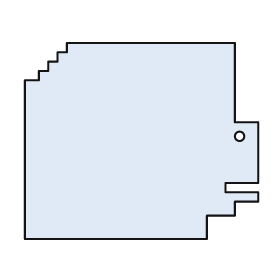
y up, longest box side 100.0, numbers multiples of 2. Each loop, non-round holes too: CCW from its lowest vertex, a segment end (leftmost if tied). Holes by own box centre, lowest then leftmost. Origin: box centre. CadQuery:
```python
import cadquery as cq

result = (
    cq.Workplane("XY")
    .moveTo(-50.0, -42.0)
    .lineTo(28.0, -42.0)
    .lineTo(28.0, -32.0)
    .lineTo(40.0, -32.0)
    .lineTo(40.0, -26.0)
    .lineTo(50.0, -26.0)
    .lineTo(50.0, -22.0)
    .lineTo(36.0, -22.0)
    .lineTo(36.0, -18.0)
    .lineTo(50.0, -18.0)
    .lineTo(50.0, 8.0)
    .lineTo(40.0, 8.0)
    .lineTo(40.0, 42.0)
    .lineTo(-32.0, 42.0)
    .lineTo(-32.0, 38.0)
    .lineTo(-36.0, 38.0)
    .lineTo(-36.0, 34.0)
    .lineTo(-40.0, 34.0)
    .lineTo(-40.0, 30.0)
    .lineTo(-44.0, 30.0)
    .lineTo(-44.0, 26.0)
    .lineTo(-50.0, 26.0)
    .close()
    .moveTo(42.0, 2.0)
    .circle(2.0)
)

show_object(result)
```